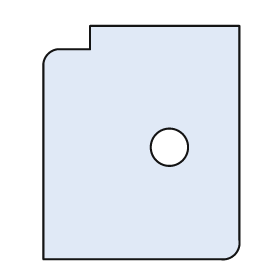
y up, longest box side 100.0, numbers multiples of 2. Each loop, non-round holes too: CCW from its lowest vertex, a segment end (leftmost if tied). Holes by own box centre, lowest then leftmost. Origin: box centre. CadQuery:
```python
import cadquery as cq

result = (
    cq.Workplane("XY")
    .moveTo(-42.0, -50.0)
    .lineTo(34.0, -50.0)
    .threePointArc((40.0, -48.0), (42.0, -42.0))
    .lineTo(42.0, 50.0)
    .lineTo(-22.0, 50.0)
    .lineTo(-22.0, 40.0)
    .lineTo(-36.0, 40.0)
    .threePointArc((-40.0, 38.0), (-42.0, 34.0))
    .close()
    .moveTo(12.0, -2.0)
    .circle(8.0)
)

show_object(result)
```